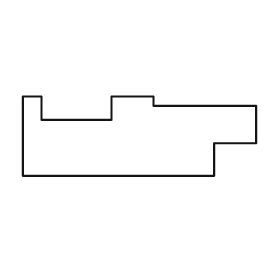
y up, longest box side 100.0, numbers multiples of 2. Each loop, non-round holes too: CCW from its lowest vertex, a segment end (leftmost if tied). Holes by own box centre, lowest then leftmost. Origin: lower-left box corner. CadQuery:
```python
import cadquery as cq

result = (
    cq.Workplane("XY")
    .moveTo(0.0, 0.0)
    .lineTo(82.0, 0.0)
    .lineTo(82.0, 14.0)
    .lineTo(100.0, 14.0)
    .lineTo(100.0, 30.0)
    .lineTo(56.0, 30.0)
    .lineTo(56.0, 34.0)
    .lineTo(38.0, 34.0)
    .lineTo(38.0, 24.0)
    .lineTo(8.0, 24.0)
    .lineTo(8.0, 34.0)
    .lineTo(0.0, 34.0)
    .close()
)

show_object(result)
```